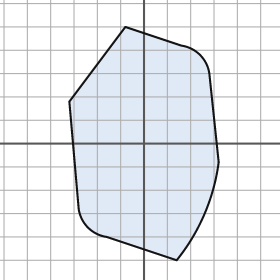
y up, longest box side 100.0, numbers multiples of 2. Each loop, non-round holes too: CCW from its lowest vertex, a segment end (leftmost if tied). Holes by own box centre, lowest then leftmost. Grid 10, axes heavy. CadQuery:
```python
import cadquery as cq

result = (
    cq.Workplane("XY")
    .moveTo(14.0, -50.0)
    .threePointArc((26.0, -30.0), (32.0, -8.0))
    .lineTo(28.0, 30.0)
    .threePointArc((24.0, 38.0), (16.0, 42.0))
    .lineTo(-8.0, 50.0)
    .lineTo(-32.0, 18.0)
    .lineTo(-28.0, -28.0)
    .threePointArc((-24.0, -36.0), (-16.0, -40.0))
    .close()
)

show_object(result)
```